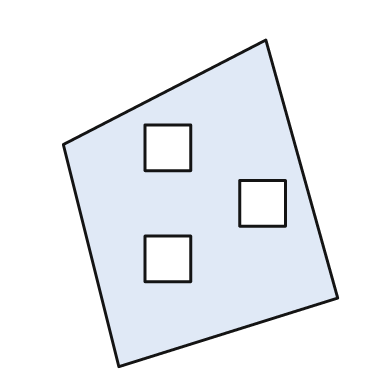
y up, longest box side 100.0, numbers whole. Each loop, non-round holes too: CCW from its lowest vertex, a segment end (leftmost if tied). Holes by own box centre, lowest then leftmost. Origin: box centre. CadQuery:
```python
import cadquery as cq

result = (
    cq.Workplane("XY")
    .moveTo(-25.0, -50.0)
    .lineTo(42.0, -29.0)
    .lineTo(20.0, 50.0)
    .lineTo(-42.0, 18.0)
    .close()
    .moveTo(-17.0, -24.0)
    .lineTo(-3.0, -24.0)
    .lineTo(-3.0, -10.0)
    .lineTo(-17.0, -10.0)
    .close()
    .moveTo(12.0, -7.0)
    .lineTo(26.0, -7.0)
    .lineTo(26.0, 7.0)
    .lineTo(12.0, 7.0)
    .close()
    .moveTo(-17.0, 10.0)
    .lineTo(-3.0, 10.0)
    .lineTo(-3.0, 24.0)
    .lineTo(-17.0, 24.0)
    .close()
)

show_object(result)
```